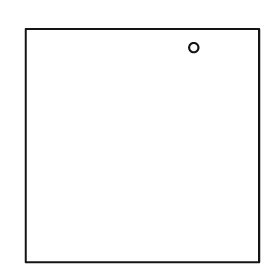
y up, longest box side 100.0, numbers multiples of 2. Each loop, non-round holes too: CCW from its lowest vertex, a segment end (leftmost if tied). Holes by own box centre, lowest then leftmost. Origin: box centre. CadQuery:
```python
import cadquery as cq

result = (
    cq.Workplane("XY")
    .moveTo(-50.0, -50.0)
    .lineTo(50.0, -50.0)
    .lineTo(50.0, 50.0)
    .lineTo(-50.0, 50.0)
    .close()
    .moveTo(22.0, 42.0)
    .circle(2.0)
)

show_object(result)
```